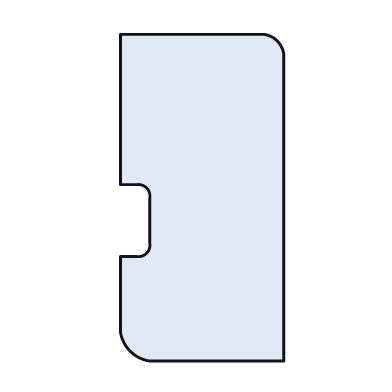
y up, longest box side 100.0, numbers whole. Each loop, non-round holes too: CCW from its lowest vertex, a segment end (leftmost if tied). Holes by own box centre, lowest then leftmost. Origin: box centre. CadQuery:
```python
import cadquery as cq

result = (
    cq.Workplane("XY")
    .moveTo(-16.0, -50.0)
    .lineTo(25.0, -50.0)
    .lineTo(25.0, 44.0)
    .threePointArc((23.0, 48.0), (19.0, 50.0))
    .lineTo(-25.0, 50.0)
    .lineTo(-25.0, 4.0)
    .lineTo(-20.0, 4.0)
    .threePointArc((-17.0, 3.0), (-16.0, 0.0))
    .lineTo(-16.0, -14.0)
    .threePointArc((-17.0, -17.0), (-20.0, -18.0))
    .lineTo(-25.0, -18.0)
    .lineTo(-25.0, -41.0)
    .threePointArc((-22.0, -47.0), (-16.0, -50.0))
    .close()
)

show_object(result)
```